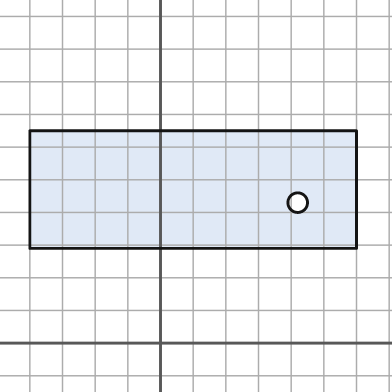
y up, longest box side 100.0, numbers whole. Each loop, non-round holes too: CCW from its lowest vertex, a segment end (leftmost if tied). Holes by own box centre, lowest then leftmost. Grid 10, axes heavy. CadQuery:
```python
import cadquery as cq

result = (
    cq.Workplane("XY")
    .moveTo(-40.0, 29.0)
    .lineTo(60.0, 29.0)
    .lineTo(60.0, 65.0)
    .lineTo(-40.0, 65.0)
    .close()
    .moveTo(42.0, 43.0)
    .circle(3.0)
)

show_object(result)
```